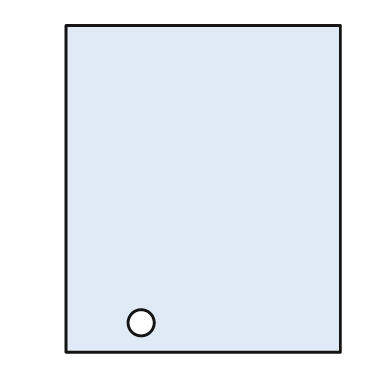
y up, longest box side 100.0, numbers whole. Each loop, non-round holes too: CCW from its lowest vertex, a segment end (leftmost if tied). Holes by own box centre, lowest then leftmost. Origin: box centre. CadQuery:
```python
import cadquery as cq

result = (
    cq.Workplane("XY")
    .moveTo(-42.0, -50.0)
    .lineTo(42.0, -50.0)
    .lineTo(42.0, 50.0)
    .lineTo(-42.0, 50.0)
    .close()
    .moveTo(-19.0, -41.0)
    .circle(4.0)
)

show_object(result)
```